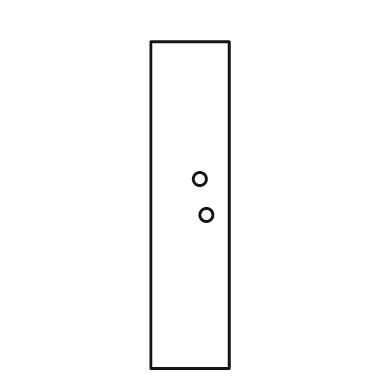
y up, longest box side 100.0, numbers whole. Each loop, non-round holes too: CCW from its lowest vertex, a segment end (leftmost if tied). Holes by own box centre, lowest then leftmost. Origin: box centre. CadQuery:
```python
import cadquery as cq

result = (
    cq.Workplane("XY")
    .moveTo(-12.0, -50.0)
    .lineTo(12.0, -50.0)
    .lineTo(12.0, 50.0)
    .lineTo(-12.0, 50.0)
    .close()
    .moveTo(5.0, -3.0)
    .circle(2.0)
    .moveTo(3.0, 8.0)
    .circle(2.0)
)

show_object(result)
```